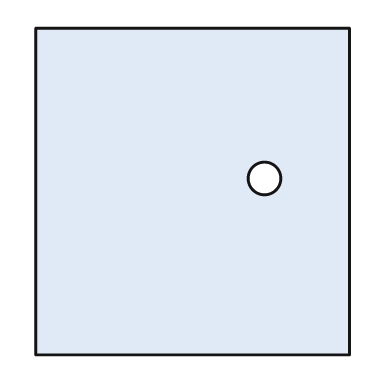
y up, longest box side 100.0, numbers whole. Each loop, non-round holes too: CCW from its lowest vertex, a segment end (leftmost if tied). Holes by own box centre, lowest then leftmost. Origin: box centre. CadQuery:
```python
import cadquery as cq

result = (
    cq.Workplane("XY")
    .moveTo(-48.0, -50.0)
    .lineTo(48.0, -50.0)
    .lineTo(48.0, 50.0)
    .lineTo(-48.0, 50.0)
    .close()
    .moveTo(22.0, 4.0)
    .circle(5.0)
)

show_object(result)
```